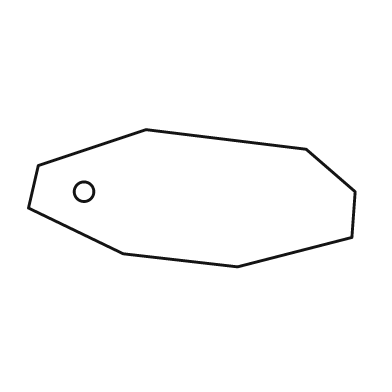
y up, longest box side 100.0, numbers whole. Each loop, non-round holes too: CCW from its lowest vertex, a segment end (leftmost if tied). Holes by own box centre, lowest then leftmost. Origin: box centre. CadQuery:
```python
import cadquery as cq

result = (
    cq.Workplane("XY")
    .moveTo(14.0, -21.0)
    .lineTo(49.0, -12.0)
    .lineTo(50.0, 2.0)
    .lineTo(35.0, 15.0)
    .lineTo(-14.0, 21.0)
    .lineTo(-47.0, 10.0)
    .lineTo(-50.0, -3.0)
    .lineTo(-21.0, -17.0)
    .close()
    .moveTo(-33.0, 2.0)
    .circle(3.0)
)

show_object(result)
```